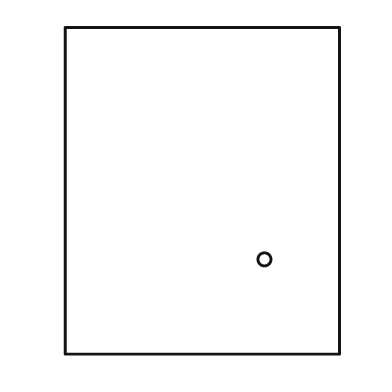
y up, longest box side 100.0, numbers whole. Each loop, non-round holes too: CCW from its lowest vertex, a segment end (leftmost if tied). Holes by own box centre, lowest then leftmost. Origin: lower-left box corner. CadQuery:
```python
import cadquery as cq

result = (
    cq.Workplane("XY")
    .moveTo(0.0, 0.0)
    .lineTo(84.0, 0.0)
    .lineTo(84.0, 100.0)
    .lineTo(0.0, 100.0)
    .close()
    .moveTo(61.0, 29.0)
    .circle(2.0)
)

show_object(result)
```